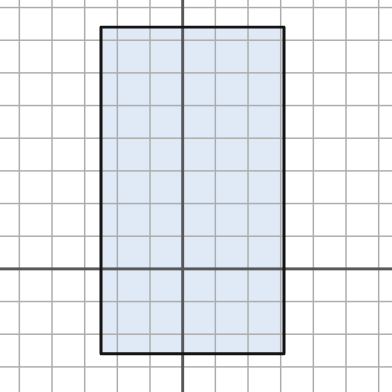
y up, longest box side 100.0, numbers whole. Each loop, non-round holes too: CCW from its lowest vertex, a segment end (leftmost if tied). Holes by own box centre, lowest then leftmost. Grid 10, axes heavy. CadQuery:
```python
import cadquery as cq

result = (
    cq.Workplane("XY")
    .moveTo(-25.0, -26.0)
    .lineTo(31.0, -26.0)
    .lineTo(31.0, 74.0)
    .lineTo(-25.0, 74.0)
    .close()
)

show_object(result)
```